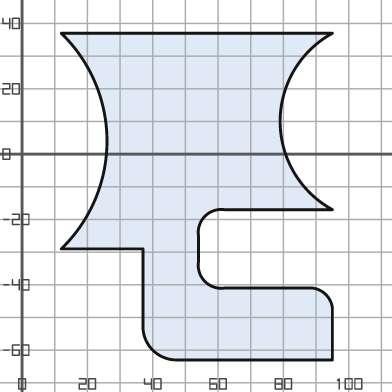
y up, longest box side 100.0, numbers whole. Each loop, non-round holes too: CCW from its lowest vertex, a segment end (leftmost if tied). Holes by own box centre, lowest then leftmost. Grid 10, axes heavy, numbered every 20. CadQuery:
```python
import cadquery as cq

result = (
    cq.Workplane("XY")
    .moveTo(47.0, -63.0)
    .lineTo(95.0, -63.0)
    .lineTo(95.0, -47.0)
    .threePointArc((93.0, -43.0), (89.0, -41.0))
    .lineTo(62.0, -41.0)
    .threePointArc((56.0, -39.0), (54.0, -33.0))
    .lineTo(54.0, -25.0)
    .threePointArc((56.0, -19.0), (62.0, -17.0))
    .lineTo(95.0, -17.0)
    .threePointArc((79.0, 10.0), (95.0, 37.0))
    .lineTo(12.0, 37.0)
    .threePointArc((26.0, 4.0), (12.0, -29.0))
    .lineTo(37.0, -29.0)
    .lineTo(37.0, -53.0)
    .threePointArc((40.0, -60.0), (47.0, -63.0))
    .close()
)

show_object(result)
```